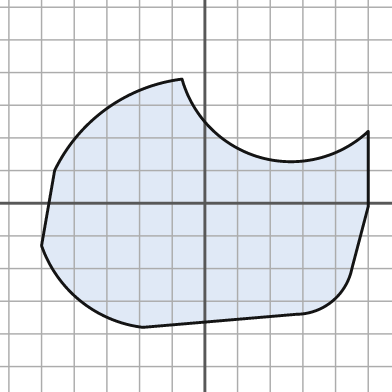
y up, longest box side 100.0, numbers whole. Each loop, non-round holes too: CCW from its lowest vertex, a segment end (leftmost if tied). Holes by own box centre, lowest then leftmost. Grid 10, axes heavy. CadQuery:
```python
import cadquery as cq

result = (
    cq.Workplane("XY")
    .moveTo(-19.0, -38.0)
    .lineTo(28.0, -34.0)
    .threePointArc((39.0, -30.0), (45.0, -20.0))
    .lineTo(50.0, -1.0)
    .lineTo(50.0, 22.0)
    .threePointArc((17.0, 14.0), (-7.0, 38.0))
    .threePointArc((-30.0, 29.0), (-46.0, 10.0))
    .lineTo(-50.0, -13.0)
    .threePointArc((-38.0, -30.0), (-19.0, -38.0))
    .close()
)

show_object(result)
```